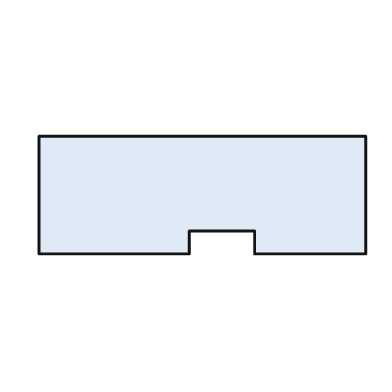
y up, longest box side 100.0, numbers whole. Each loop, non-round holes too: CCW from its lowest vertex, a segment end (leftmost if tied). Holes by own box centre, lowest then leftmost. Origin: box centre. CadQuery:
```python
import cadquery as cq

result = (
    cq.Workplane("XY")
    .moveTo(-50.0, -18.0)
    .lineTo(-4.0, -18.0)
    .lineTo(-4.0, -11.0)
    .lineTo(16.0, -11.0)
    .lineTo(16.0, -18.0)
    .lineTo(50.0, -18.0)
    .lineTo(50.0, 18.0)
    .lineTo(-50.0, 18.0)
    .close()
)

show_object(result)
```